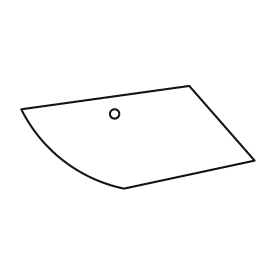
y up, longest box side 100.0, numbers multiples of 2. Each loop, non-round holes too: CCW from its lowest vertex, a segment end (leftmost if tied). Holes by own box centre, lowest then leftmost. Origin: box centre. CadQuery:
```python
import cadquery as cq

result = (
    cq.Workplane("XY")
    .moveTo(-6.0, -22.0)
    .lineTo(50.0, -10.0)
    .lineTo(22.0, 22.0)
    .lineTo(-50.0, 12.0)
    .threePointArc((-32.0, -10.0), (-6.0, -22.0))
    .close()
    .moveTo(-10.0, 10.0)
    .circle(2.0)
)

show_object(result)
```